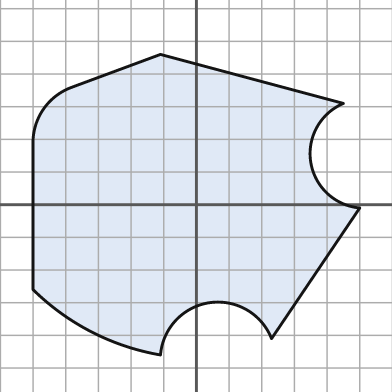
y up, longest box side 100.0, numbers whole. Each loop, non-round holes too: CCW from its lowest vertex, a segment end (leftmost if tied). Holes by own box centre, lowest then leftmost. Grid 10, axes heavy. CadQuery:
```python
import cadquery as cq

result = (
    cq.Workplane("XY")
    .moveTo(-11.0, -46.0)
    .threePointArc((4.0, -30.0), (23.0, -41.0))
    .lineTo(50.0, -1.0)
    .threePointArc((35.0, 13.0), (45.0, 31.0))
    .lineTo(-11.0, 46.0)
    .lineTo(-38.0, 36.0)
    .threePointArc((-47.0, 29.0), (-50.0, 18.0))
    .lineTo(-50.0, -26.0)
    .threePointArc((-32.0, -39.0), (-11.0, -46.0))
    .close()
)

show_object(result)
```